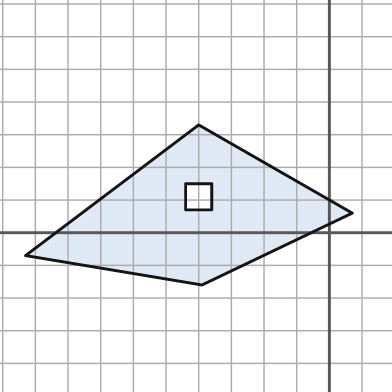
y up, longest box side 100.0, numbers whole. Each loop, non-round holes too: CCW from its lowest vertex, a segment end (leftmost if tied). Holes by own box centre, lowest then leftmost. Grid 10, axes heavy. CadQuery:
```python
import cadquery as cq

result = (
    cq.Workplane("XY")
    .moveTo(-39.0, -16.0)
    .lineTo(7.0, 6.0)
    .lineTo(-40.0, 33.0)
    .lineTo(-93.0, -7.0)
    .close()
    .moveTo(-44.0, 7.0)
    .lineTo(-36.0, 7.0)
    .lineTo(-36.0, 15.0)
    .lineTo(-44.0, 15.0)
    .close()
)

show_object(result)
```